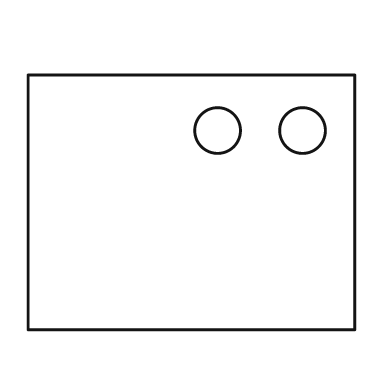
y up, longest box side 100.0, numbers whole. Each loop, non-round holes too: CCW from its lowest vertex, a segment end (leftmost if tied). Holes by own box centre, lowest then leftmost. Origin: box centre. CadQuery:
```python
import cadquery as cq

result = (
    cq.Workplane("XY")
    .moveTo(-50.0, -39.0)
    .lineTo(50.0, -39.0)
    .lineTo(50.0, 39.0)
    .lineTo(-50.0, 39.0)
    .close()
    .moveTo(8.0, 22.0)
    .circle(7.0)
    .moveTo(34.0, 22.0)
    .circle(7.0)
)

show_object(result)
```